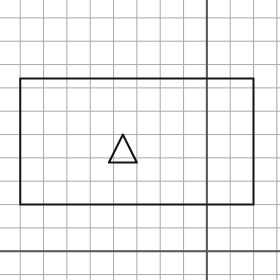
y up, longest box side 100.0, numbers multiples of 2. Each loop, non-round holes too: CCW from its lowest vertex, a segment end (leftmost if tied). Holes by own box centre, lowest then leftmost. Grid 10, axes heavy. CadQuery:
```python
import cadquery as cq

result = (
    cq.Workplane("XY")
    .moveTo(-80.0, 20.0)
    .lineTo(20.0, 20.0)
    .lineTo(20.0, 74.0)
    .lineTo(-80.0, 74.0)
    .close()
    .moveTo(-42.0, 38.0)
    .lineTo(-30.0, 38.0)
    .lineTo(-36.0, 50.0)
    .close()
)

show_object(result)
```